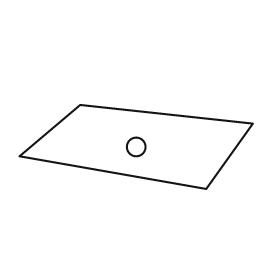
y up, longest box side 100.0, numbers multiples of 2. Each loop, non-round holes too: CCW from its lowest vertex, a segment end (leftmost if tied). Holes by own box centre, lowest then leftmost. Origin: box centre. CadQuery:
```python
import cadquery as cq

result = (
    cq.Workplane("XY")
    .moveTo(30.0, -18.0)
    .lineTo(50.0, 10.0)
    .lineTo(-24.0, 18.0)
    .lineTo(-50.0, -4.0)
    .close()
    .moveTo(0.0, 0.0)
    .circle(4.0)
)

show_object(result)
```